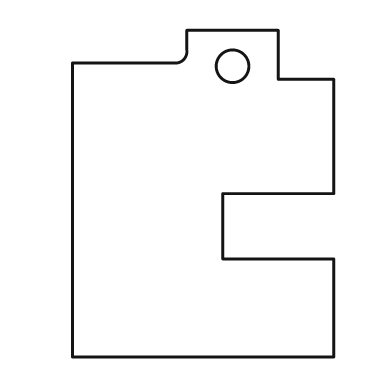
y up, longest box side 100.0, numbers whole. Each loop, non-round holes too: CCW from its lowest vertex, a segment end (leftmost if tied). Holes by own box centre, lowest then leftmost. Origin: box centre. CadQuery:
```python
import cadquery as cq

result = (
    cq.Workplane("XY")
    .moveTo(-40.0, -50.0)
    .lineTo(40.0, -50.0)
    .lineTo(40.0, -20.0)
    .lineTo(6.0, -20.0)
    .lineTo(6.0, 0.0)
    .lineTo(40.0, 0.0)
    .lineTo(40.0, 35.0)
    .lineTo(23.0, 35.0)
    .lineTo(23.0, 50.0)
    .lineTo(-5.0, 50.0)
    .lineTo(-5.0, 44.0)
    .threePointArc((-6.0, 41.0), (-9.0, 40.0))
    .lineTo(-40.0, 40.0)
    .close()
    .moveTo(9.0, 39.0)
    .circle(5.0)
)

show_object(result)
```